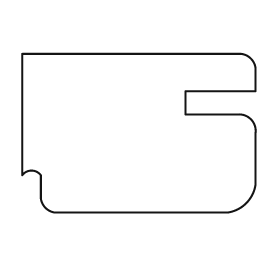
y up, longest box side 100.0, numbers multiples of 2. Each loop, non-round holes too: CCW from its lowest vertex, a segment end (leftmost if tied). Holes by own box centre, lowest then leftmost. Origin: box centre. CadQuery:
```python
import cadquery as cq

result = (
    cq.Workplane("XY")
    .moveTo(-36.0, -34.0)
    .lineTo(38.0, -34.0)
    .threePointArc((46.0, -30.0), (50.0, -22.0))
    .lineTo(50.0, 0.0)
    .threePointArc((48.0, 6.0), (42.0, 8.0))
    .lineTo(20.0, 8.0)
    .lineTo(20.0, 18.0)
    .lineTo(50.0, 18.0)
    .lineTo(50.0, 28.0)
    .threePointArc((48.0, 32.0), (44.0, 34.0))
    .lineTo(-50.0, 34.0)
    .lineTo(-50.0, -18.0)
    .threePointArc((-46.0, -16.0), (-42.0, -18.0))
    .lineTo(-42.0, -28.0)
    .threePointArc((-40.0, -32.0), (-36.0, -34.0))
    .close()
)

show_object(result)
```